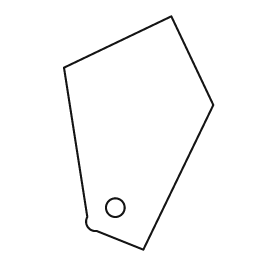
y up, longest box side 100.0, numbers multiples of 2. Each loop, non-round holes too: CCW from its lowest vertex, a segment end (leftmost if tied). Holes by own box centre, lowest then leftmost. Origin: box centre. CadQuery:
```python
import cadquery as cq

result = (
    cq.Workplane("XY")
    .moveTo(2.0, -50.0)
    .lineTo(32.0, 12.0)
    .lineTo(14.0, 50.0)
    .lineTo(-32.0, 28.0)
    .lineTo(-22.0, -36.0)
    .threePointArc((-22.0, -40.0), (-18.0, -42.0))
    .close()
    .moveTo(-10.0, -32.0)
    .circle(4.0)
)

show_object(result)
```